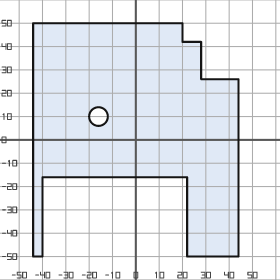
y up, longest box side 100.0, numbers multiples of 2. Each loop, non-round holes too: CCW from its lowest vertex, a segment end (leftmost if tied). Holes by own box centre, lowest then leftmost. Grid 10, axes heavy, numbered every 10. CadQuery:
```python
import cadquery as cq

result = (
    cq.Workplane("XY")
    .moveTo(-44.0, -50.0)
    .lineTo(-40.0, -50.0)
    .lineTo(-40.0, -16.0)
    .lineTo(22.0, -16.0)
    .lineTo(22.0, -50.0)
    .lineTo(44.0, -50.0)
    .lineTo(44.0, 26.0)
    .lineTo(28.0, 26.0)
    .lineTo(28.0, 42.0)
    .lineTo(20.0, 42.0)
    .lineTo(20.0, 50.0)
    .lineTo(-44.0, 50.0)
    .close()
    .moveTo(-16.0, 10.0)
    .circle(4.0)
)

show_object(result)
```